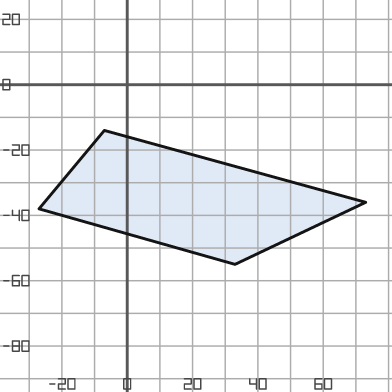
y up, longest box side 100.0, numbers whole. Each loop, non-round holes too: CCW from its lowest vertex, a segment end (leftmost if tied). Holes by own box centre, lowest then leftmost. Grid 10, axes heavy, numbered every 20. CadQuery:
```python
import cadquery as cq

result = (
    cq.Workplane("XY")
    .moveTo(33.0, -55.0)
    .lineTo(73.0, -36.0)
    .lineTo(-7.0, -14.0)
    .lineTo(-27.0, -38.0)
    .close()
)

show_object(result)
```